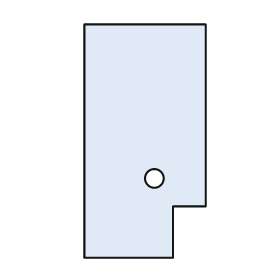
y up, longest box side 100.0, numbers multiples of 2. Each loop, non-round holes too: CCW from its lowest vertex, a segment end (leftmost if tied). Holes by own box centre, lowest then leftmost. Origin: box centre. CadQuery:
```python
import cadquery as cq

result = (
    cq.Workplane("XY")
    .moveTo(-26.0, -50.0)
    .lineTo(12.0, -50.0)
    .lineTo(12.0, -28.0)
    .lineTo(26.0, -28.0)
    .lineTo(26.0, 50.0)
    .lineTo(-26.0, 50.0)
    .close()
    .moveTo(4.0, -16.0)
    .circle(4.0)
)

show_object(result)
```